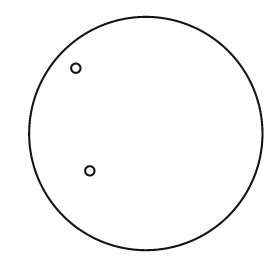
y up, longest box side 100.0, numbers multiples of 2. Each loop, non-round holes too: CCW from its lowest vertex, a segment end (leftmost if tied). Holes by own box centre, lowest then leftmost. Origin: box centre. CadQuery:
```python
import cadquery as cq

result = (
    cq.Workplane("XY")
    .moveTo(0.0, 0.0)
    .circle(50.0)
    .moveTo(-24.0, -16.0)
    .circle(2.0)
    .moveTo(-30.0, 28.0)
    .circle(2.0)
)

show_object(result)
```